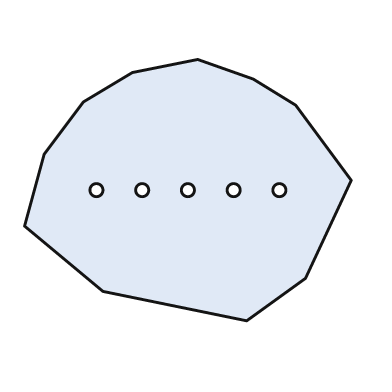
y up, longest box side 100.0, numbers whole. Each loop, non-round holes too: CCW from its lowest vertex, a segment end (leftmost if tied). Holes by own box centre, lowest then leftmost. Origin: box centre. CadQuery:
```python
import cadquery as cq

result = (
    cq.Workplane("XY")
    .moveTo(18.0, -40.0)
    .lineTo(36.0, -27.0)
    .lineTo(50.0, 3.0)
    .lineTo(33.0, 26.0)
    .lineTo(20.0, 34.0)
    .lineTo(3.0, 40.0)
    .lineTo(-17.0, 36.0)
    .lineTo(-32.0, 27.0)
    .lineTo(-44.0, 11.0)
    .lineTo(-50.0, -11.0)
    .lineTo(-26.0, -31.0)
    .close()
    .moveTo(-28.0, 0.0)
    .circle(2.0)
    .moveTo(-14.0, 0.0)
    .circle(2.0)
    .moveTo(0.0, 0.0)
    .circle(2.0)
    .moveTo(14.0, 0.0)
    .circle(2.0)
    .moveTo(28.0, 0.0)
    .circle(2.0)
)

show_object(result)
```